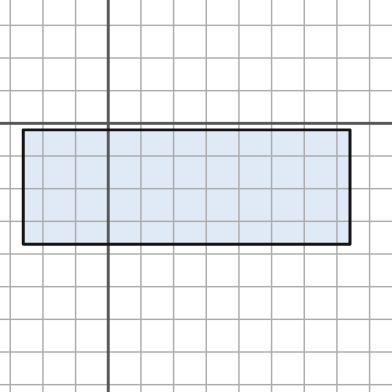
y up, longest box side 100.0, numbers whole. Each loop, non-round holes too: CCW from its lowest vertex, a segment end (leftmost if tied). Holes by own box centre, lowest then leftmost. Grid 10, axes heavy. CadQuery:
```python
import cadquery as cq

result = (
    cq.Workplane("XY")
    .moveTo(-26.0, -37.0)
    .lineTo(74.0, -37.0)
    .lineTo(74.0, -2.0)
    .lineTo(-26.0, -2.0)
    .close()
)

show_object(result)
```